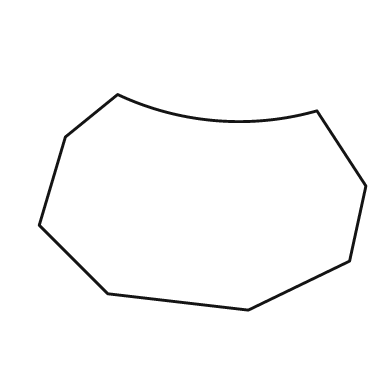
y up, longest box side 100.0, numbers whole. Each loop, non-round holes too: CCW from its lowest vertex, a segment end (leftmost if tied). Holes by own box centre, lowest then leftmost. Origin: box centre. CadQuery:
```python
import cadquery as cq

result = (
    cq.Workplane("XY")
    .moveTo(14.0, -33.0)
    .lineTo(45.0, -18.0)
    .lineTo(50.0, 5.0)
    .lineTo(35.0, 28.0)
    .threePointArc((4.0, 25.0), (-26.0, 33.0))
    .lineTo(-42.0, 20.0)
    .lineTo(-50.0, -7.0)
    .lineTo(-29.0, -28.0)
    .close()
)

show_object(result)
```